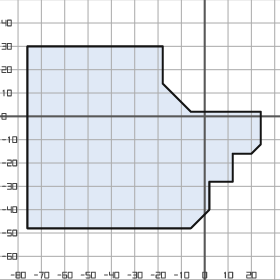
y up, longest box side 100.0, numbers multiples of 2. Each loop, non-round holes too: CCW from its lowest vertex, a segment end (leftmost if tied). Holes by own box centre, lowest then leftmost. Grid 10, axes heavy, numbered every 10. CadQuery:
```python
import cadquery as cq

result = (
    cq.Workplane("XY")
    .moveTo(-76.0, -48.0)
    .lineTo(-6.0, -48.0)
    .lineTo(2.0, -40.0)
    .lineTo(2.0, -28.0)
    .lineTo(12.0, -28.0)
    .lineTo(12.0, -16.0)
    .lineTo(20.0, -16.0)
    .lineTo(24.0, -12.0)
    .lineTo(24.0, 2.0)
    .lineTo(-6.0, 2.0)
    .lineTo(-18.0, 14.0)
    .lineTo(-18.0, 30.0)
    .lineTo(-76.0, 30.0)
    .close()
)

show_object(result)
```